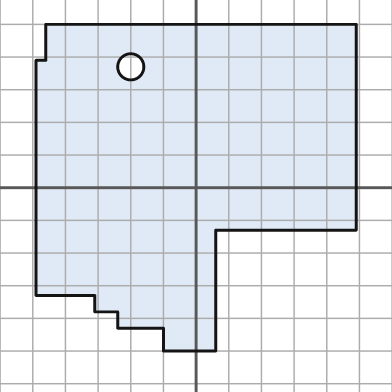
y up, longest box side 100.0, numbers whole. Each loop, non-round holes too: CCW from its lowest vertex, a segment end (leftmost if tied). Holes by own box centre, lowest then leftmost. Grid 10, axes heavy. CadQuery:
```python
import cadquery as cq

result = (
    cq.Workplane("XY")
    .moveTo(-10.0, -50.0)
    .lineTo(6.0, -50.0)
    .lineTo(6.0, -13.0)
    .lineTo(49.0, -13.0)
    .lineTo(49.0, 50.0)
    .lineTo(-46.0, 50.0)
    .lineTo(-46.0, 39.0)
    .lineTo(-49.0, 39.0)
    .lineTo(-49.0, -33.0)
    .lineTo(-31.0, -33.0)
    .lineTo(-31.0, -38.0)
    .lineTo(-24.0, -38.0)
    .lineTo(-24.0, -43.0)
    .lineTo(-10.0, -43.0)
    .close()
    .moveTo(-20.0, 37.0)
    .circle(4.0)
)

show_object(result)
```